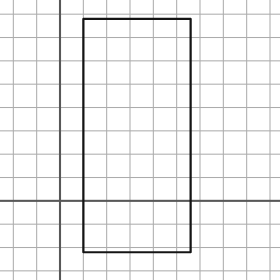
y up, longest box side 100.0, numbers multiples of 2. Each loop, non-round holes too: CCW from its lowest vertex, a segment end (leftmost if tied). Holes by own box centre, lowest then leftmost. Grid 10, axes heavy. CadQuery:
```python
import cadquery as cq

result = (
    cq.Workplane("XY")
    .moveTo(10.0, -22.0)
    .lineTo(56.0, -22.0)
    .lineTo(56.0, 78.0)
    .lineTo(10.0, 78.0)
    .close()
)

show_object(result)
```